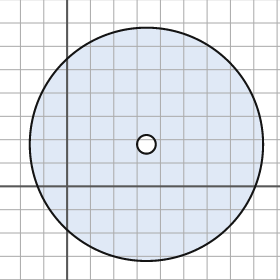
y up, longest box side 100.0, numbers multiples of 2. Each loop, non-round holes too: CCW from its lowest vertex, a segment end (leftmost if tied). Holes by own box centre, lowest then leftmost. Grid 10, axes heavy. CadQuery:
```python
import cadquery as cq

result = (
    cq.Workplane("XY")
    .moveTo(34.0, 18.0)
    .circle(50.0)
    .moveTo(34.0, 18.0)
    .circle(4.0)
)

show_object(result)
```